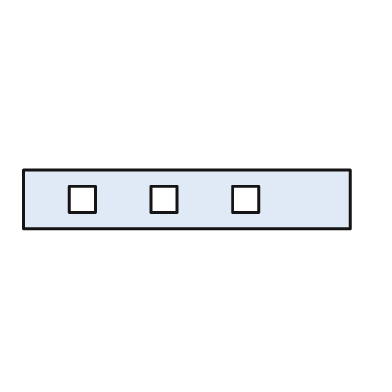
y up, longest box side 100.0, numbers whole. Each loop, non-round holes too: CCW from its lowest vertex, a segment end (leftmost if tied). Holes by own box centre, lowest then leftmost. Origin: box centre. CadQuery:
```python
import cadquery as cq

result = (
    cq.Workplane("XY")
    .moveTo(-50.0, -9.0)
    .lineTo(50.0, -9.0)
    .lineTo(50.0, 9.0)
    .lineTo(-50.0, 9.0)
    .close()
    .moveTo(-36.0, -4.0)
    .lineTo(-28.0, -4.0)
    .lineTo(-28.0, 4.0)
    .lineTo(-36.0, 4.0)
    .close()
    .moveTo(-11.0, -4.0)
    .lineTo(-3.0, -4.0)
    .lineTo(-3.0, 4.0)
    .lineTo(-11.0, 4.0)
    .close()
    .moveTo(14.0, -4.0)
    .lineTo(22.0, -4.0)
    .lineTo(22.0, 4.0)
    .lineTo(14.0, 4.0)
    .close()
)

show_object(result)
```